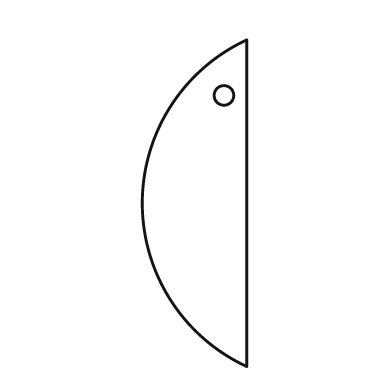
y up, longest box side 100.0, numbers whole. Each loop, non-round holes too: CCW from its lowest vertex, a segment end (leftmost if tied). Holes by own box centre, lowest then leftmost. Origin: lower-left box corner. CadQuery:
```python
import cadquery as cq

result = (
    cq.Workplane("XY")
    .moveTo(32.0, 0.0)
    .lineTo(32.0, 100.0)
    .threePointArc((0.0, 50.0), (32.0, 0.0))
    .close()
    .moveTo(25.0, 83.0)
    .circle(3.0)
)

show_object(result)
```